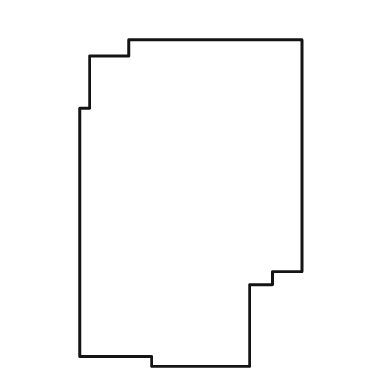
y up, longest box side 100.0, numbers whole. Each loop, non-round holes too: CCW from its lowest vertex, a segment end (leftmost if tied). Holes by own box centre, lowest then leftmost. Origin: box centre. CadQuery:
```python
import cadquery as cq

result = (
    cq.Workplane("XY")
    .moveTo(-12.0, -50.0)
    .lineTo(18.0, -50.0)
    .lineTo(18.0, -25.0)
    .lineTo(25.0, -25.0)
    .lineTo(25.0, -21.0)
    .lineTo(34.0, -21.0)
    .lineTo(34.0, 50.0)
    .lineTo(-19.0, 50.0)
    .lineTo(-19.0, 45.0)
    .lineTo(-31.0, 45.0)
    .lineTo(-31.0, 29.0)
    .lineTo(-34.0, 29.0)
    .lineTo(-34.0, -47.0)
    .lineTo(-12.0, -47.0)
    .close()
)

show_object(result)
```